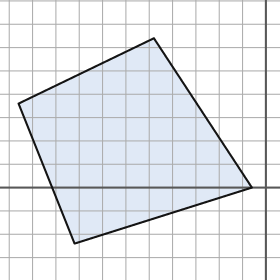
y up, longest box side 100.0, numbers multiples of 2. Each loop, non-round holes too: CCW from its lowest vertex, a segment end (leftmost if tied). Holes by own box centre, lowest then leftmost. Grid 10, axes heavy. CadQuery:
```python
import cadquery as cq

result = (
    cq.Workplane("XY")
    .moveTo(-82.0, -24.0)
    .lineTo(-6.0, 0.0)
    .lineTo(-48.0, 64.0)
    .lineTo(-106.0, 36.0)
    .close()
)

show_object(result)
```